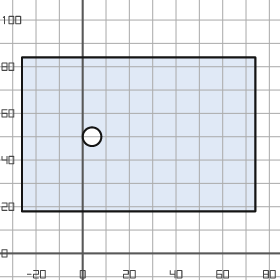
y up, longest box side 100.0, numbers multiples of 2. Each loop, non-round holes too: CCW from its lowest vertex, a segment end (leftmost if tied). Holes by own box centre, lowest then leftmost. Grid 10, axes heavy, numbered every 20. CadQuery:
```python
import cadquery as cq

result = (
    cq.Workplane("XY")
    .moveTo(-26.0, 18.0)
    .lineTo(74.0, 18.0)
    .lineTo(74.0, 84.0)
    .lineTo(-26.0, 84.0)
    .close()
    .moveTo(4.0, 50.0)
    .circle(4.0)
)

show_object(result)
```